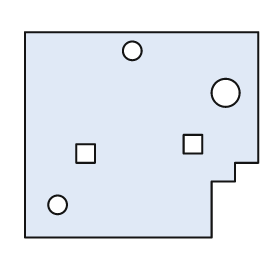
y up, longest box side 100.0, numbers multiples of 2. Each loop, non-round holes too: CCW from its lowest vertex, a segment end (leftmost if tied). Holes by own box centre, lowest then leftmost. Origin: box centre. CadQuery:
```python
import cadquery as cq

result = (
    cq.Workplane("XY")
    .moveTo(-50.0, -44.0)
    .lineTo(30.0, -44.0)
    .lineTo(30.0, -20.0)
    .lineTo(40.0, -20.0)
    .lineTo(40.0, -12.0)
    .lineTo(50.0, -12.0)
    .lineTo(50.0, 44.0)
    .lineTo(-50.0, 44.0)
    .close()
    .moveTo(-36.0, -30.0)
    .circle(4.0)
    .moveTo(-28.0, -12.0)
    .lineTo(-20.0, -12.0)
    .lineTo(-20.0, -4.0)
    .lineTo(-28.0, -4.0)
    .close()
    .moveTo(18.0, -8.0)
    .lineTo(26.0, -8.0)
    .lineTo(26.0, 0.0)
    .lineTo(18.0, 0.0)
    .close()
    .moveTo(36.0, 18.0)
    .circle(6.0)
    .moveTo(-4.0, 36.0)
    .circle(4.0)
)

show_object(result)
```